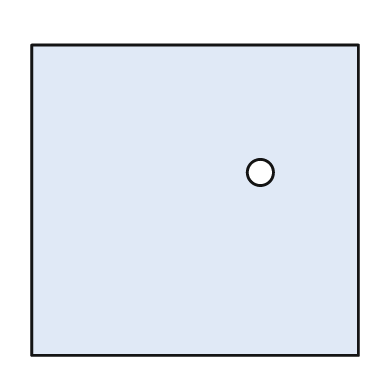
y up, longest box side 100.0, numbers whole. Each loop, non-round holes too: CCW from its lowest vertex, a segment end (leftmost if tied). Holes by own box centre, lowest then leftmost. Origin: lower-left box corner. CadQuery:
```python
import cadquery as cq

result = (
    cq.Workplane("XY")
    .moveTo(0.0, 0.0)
    .lineTo(100.0, 0.0)
    .lineTo(100.0, 95.0)
    .lineTo(0.0, 95.0)
    .close()
    .moveTo(70.0, 56.0)
    .circle(4.0)
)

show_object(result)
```